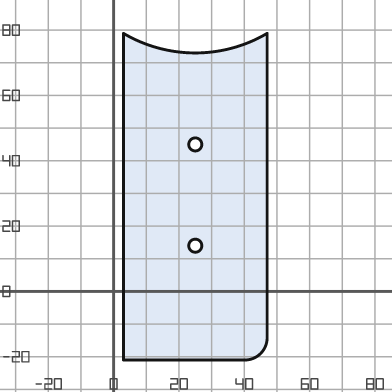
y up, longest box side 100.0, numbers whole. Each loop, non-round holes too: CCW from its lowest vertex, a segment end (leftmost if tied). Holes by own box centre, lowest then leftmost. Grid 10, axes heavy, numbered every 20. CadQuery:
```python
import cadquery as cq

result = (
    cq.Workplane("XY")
    .moveTo(3.0, -21.0)
    .lineTo(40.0, -21.0)
    .threePointArc((45.0, -19.0), (47.0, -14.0))
    .lineTo(47.0, 79.0)
    .threePointArc((25.0, 73.0), (3.0, 79.0))
    .close()
    .moveTo(25.0, 14.0)
    .circle(2.0)
    .moveTo(25.0, 45.0)
    .circle(2.0)
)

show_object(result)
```